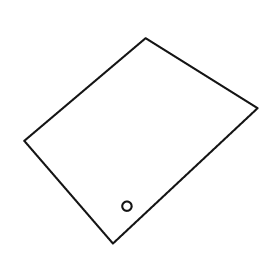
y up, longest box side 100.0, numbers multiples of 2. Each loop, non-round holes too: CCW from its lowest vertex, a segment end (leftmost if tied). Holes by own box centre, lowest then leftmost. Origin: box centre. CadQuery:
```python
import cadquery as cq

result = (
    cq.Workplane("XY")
    .moveTo(-12.0, -44.0)
    .lineTo(50.0, 14.0)
    .lineTo(2.0, 44.0)
    .lineTo(-50.0, 0.0)
    .close()
    .moveTo(-6.0, -28.0)
    .circle(2.0)
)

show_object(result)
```